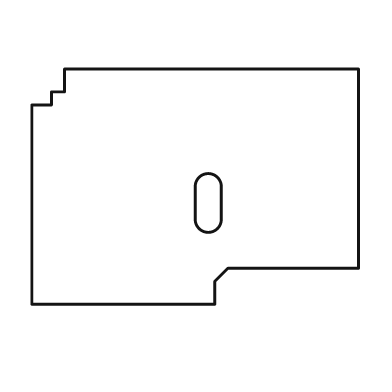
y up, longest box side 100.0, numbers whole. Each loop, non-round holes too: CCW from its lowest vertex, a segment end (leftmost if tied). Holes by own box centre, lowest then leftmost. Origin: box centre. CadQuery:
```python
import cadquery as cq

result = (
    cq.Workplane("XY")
    .moveTo(-50.0, -36.0)
    .lineTo(6.0, -36.0)
    .lineTo(6.0, -29.0)
    .lineTo(10.0, -25.0)
    .lineTo(50.0, -25.0)
    .lineTo(50.0, 36.0)
    .lineTo(-40.0, 36.0)
    .lineTo(-40.0, 29.0)
    .lineTo(-44.0, 29.0)
    .lineTo(-44.0, 25.0)
    .lineTo(-50.0, 25.0)
    .close()
    .moveTo(0.0, -10.0)
    .threePointArc((4.0, -14.0), (8.0, -10.0))
    .lineTo(8.0, 0.0)
    .threePointArc((4.0, 4.0), (0.0, 0.0))
    .close()
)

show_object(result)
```